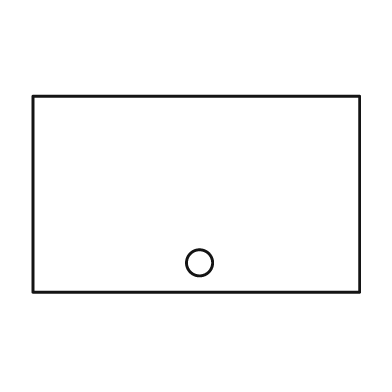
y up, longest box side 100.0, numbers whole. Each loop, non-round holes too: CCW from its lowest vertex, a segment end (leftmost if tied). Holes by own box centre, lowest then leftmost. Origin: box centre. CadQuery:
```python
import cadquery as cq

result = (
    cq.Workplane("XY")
    .moveTo(-50.0, -30.0)
    .lineTo(50.0, -30.0)
    .lineTo(50.0, 30.0)
    .lineTo(-50.0, 30.0)
    .close()
    .moveTo(1.0, -21.0)
    .circle(4.0)
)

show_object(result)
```